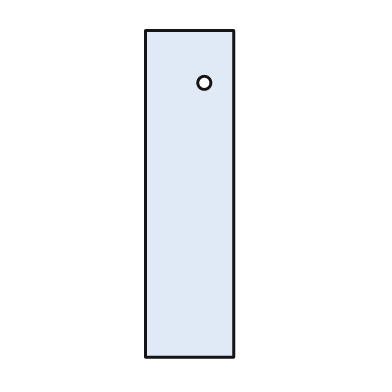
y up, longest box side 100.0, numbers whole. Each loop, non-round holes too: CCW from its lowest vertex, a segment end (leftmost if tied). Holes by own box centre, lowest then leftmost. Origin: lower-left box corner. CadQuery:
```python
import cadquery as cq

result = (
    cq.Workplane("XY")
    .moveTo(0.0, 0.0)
    .lineTo(27.0, 0.0)
    .lineTo(27.0, 100.0)
    .lineTo(0.0, 100.0)
    .close()
    .moveTo(18.0, 84.0)
    .circle(2.0)
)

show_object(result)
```